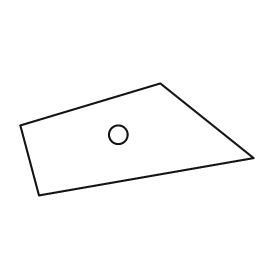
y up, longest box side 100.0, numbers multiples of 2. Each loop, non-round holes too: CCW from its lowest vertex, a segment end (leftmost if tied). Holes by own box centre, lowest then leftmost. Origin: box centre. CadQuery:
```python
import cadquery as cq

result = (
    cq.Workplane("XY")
    .moveTo(-42.0, -24.0)
    .lineTo(50.0, -8.0)
    .lineTo(10.0, 24.0)
    .lineTo(-50.0, 6.0)
    .close()
    .moveTo(-8.0, 2.0)
    .circle(4.0)
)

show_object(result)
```